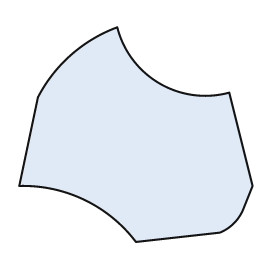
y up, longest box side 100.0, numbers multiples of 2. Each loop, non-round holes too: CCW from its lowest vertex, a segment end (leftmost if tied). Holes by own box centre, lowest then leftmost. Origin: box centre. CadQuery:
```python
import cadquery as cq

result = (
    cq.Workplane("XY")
    .moveTo(0.0, -46.0)
    .lineTo(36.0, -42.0)
    .threePointArc((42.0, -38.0), (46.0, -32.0))
    .lineTo(50.0, -22.0)
    .lineTo(40.0, 18.0)
    .threePointArc((10.0, 22.0), (-8.0, 46.0))
    .threePointArc((-28.0, 34.0), (-42.0, 16.0))
    .lineTo(-50.0, -22.0)
    .threePointArc((-22.0, -28.0), (0.0, -46.0))
    .close()
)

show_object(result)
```